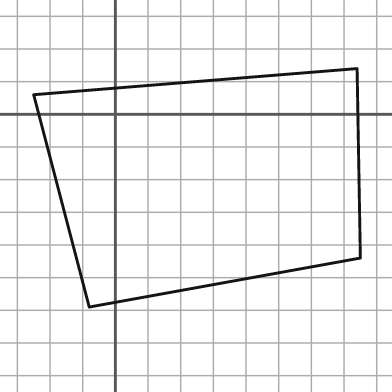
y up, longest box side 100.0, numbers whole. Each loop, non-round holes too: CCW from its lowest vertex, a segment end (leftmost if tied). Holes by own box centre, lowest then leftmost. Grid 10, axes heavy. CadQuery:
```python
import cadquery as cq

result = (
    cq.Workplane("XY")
    .moveTo(-8.0, -59.0)
    .lineTo(75.0, -44.0)
    .lineTo(74.0, 14.0)
    .lineTo(-25.0, 6.0)
    .close()
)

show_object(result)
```